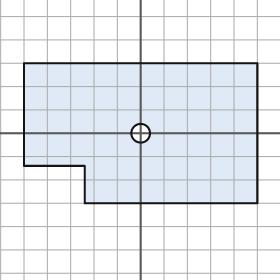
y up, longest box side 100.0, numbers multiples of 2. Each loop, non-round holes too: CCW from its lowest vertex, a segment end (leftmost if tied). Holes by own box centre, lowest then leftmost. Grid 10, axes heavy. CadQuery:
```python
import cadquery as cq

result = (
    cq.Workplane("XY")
    .moveTo(-24.0, -30.0)
    .lineTo(50.0, -30.0)
    .lineTo(50.0, 30.0)
    .lineTo(-50.0, 30.0)
    .lineTo(-50.0, -14.0)
    .lineTo(-24.0, -14.0)
    .close()
    .moveTo(0.0, 0.0)
    .circle(4.0)
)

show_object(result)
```